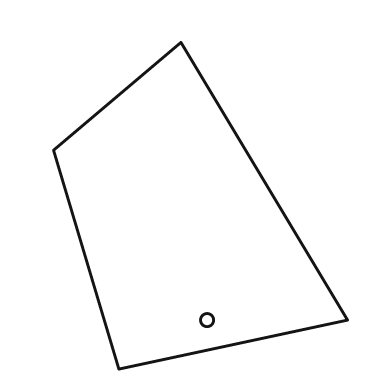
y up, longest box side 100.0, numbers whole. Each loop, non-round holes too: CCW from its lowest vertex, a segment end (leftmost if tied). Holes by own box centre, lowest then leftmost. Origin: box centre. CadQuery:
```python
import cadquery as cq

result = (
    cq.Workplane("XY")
    .moveTo(-25.0, -50.0)
    .lineTo(45.0, -35.0)
    .lineTo(-6.0, 50.0)
    .lineTo(-45.0, 17.0)
    .close()
    .moveTo(2.0, -35.0)
    .circle(2.0)
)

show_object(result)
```